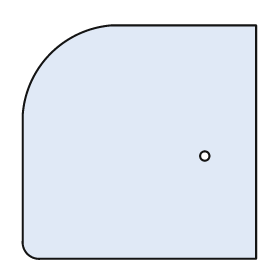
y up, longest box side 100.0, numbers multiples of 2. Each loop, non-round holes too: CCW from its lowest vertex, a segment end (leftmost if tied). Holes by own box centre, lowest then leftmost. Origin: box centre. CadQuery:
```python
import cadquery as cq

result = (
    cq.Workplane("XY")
    .moveTo(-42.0, -50.0)
    .lineTo(50.0, -50.0)
    .lineTo(50.0, 50.0)
    .lineTo(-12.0, 50.0)
    .threePointArc((-38.0, 38.0), (-50.0, 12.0))
    .lineTo(-50.0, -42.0)
    .threePointArc((-48.0, -48.0), (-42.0, -50.0))
    .close()
    .moveTo(28.0, -6.0)
    .circle(2.0)
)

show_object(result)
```